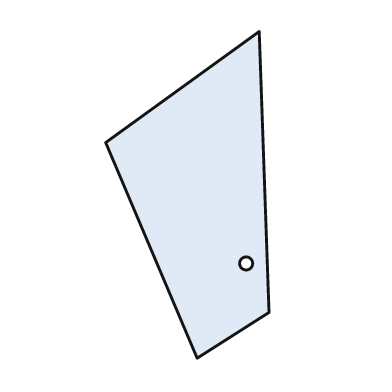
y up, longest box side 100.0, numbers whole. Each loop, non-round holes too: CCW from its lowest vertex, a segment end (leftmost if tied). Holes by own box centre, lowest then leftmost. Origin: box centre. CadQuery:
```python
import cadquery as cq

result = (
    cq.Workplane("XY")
    .moveTo(3.0, -50.0)
    .lineTo(25.0, -36.0)
    .lineTo(22.0, 50.0)
    .lineTo(-25.0, 16.0)
    .close()
    .moveTo(18.0, -21.0)
    .circle(2.0)
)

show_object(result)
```